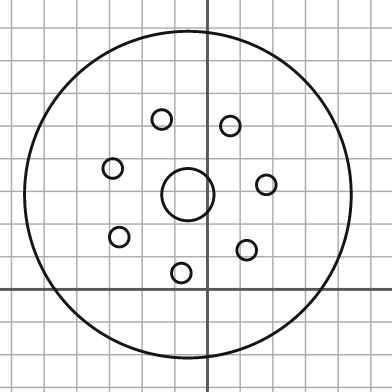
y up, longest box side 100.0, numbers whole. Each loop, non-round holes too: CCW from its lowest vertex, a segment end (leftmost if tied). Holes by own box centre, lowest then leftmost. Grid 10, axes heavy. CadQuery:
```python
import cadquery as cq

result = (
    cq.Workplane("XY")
    .moveTo(-6.0, 29.0)
    .circle(50.0)
    .moveTo(-8.0, 5.0)
    .circle(3.0)
    .moveTo(12.0, 12.0)
    .circle(3.0)
    .moveTo(-27.0, 16.0)
    .circle(3.0)
    .moveTo(-6.0, 29.0)
    .circle(8.0)
    .moveTo(18.0, 32.0)
    .circle(3.0)
    .moveTo(-29.0, 37.0)
    .circle(3.0)
    .moveTo(7.0, 50.0)
    .circle(3.0)
    .moveTo(-14.0, 52.0)
    .circle(3.0)
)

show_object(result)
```